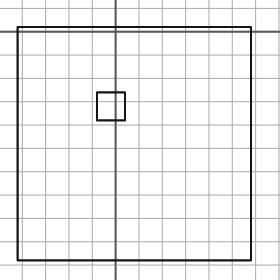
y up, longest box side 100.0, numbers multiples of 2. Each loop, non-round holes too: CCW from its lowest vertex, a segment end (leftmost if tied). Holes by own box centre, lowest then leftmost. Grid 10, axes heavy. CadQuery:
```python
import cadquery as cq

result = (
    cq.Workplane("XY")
    .moveTo(-42.0, -98.0)
    .lineTo(58.0, -98.0)
    .lineTo(58.0, 2.0)
    .lineTo(-42.0, 2.0)
    .close()
    .moveTo(-8.0, -38.0)
    .lineTo(4.0, -38.0)
    .lineTo(4.0, -26.0)
    .lineTo(-8.0, -26.0)
    .close()
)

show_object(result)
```